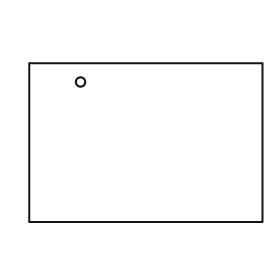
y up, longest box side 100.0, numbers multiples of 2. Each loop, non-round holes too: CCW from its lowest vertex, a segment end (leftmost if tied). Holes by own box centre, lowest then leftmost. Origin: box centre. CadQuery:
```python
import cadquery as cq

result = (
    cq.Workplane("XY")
    .moveTo(-50.0, -34.0)
    .lineTo(50.0, -34.0)
    .lineTo(50.0, 34.0)
    .lineTo(-50.0, 34.0)
    .close()
    .moveTo(-28.0, 26.0)
    .circle(2.0)
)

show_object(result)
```